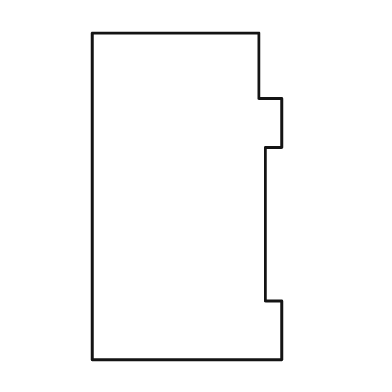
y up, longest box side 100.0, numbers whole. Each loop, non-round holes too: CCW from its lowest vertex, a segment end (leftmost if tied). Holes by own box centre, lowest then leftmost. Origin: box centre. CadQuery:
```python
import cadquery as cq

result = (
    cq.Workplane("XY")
    .moveTo(-29.0, -50.0)
    .lineTo(29.0, -50.0)
    .lineTo(29.0, -32.0)
    .lineTo(24.0, -32.0)
    .lineTo(24.0, 15.0)
    .lineTo(29.0, 15.0)
    .lineTo(29.0, 30.0)
    .lineTo(22.0, 30.0)
    .lineTo(22.0, 50.0)
    .lineTo(-29.0, 50.0)
    .close()
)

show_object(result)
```